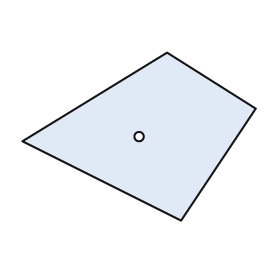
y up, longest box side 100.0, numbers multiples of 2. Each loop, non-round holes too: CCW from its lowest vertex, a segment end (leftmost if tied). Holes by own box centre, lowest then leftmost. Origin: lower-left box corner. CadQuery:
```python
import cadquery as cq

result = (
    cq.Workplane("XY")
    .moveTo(68.0, 0.0)
    .lineTo(100.0, 48.0)
    .lineTo(62.0, 72.0)
    .lineTo(0.0, 34.0)
    .close()
    .moveTo(50.0, 36.0)
    .circle(2.0)
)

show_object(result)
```